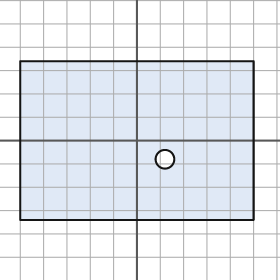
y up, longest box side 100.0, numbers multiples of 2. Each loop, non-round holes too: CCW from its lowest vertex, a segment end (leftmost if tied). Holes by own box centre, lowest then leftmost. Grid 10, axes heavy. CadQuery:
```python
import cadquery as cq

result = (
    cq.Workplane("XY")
    .moveTo(-50.0, -34.0)
    .lineTo(50.0, -34.0)
    .lineTo(50.0, 34.0)
    .lineTo(-50.0, 34.0)
    .close()
    .moveTo(12.0, -8.0)
    .circle(4.0)
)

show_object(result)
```